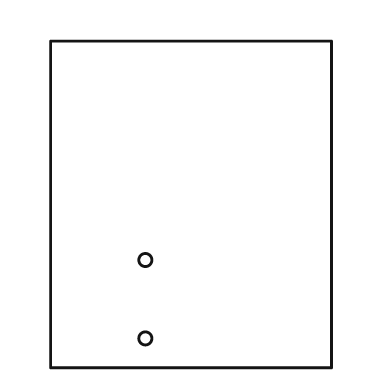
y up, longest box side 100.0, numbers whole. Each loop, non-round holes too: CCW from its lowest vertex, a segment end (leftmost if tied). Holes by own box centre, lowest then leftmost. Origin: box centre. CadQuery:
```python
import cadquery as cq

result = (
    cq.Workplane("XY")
    .moveTo(-43.0, -50.0)
    .lineTo(43.0, -50.0)
    .lineTo(43.0, 50.0)
    .lineTo(-43.0, 50.0)
    .close()
    .moveTo(-14.0, -41.0)
    .circle(2.0)
    .moveTo(-14.0, -17.0)
    .circle(2.0)
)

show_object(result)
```